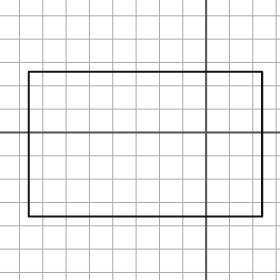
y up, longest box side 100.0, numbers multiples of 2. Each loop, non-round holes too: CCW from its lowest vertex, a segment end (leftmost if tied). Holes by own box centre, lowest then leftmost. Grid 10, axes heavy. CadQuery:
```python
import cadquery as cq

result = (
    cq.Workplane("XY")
    .moveTo(-76.0, -36.0)
    .lineTo(24.0, -36.0)
    .lineTo(24.0, 26.0)
    .lineTo(-76.0, 26.0)
    .close()
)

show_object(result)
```